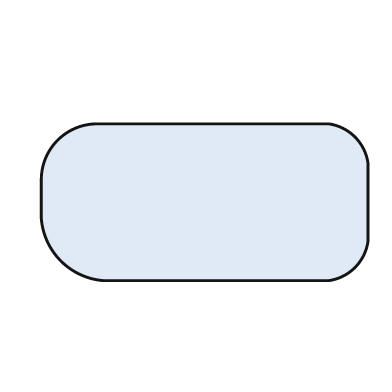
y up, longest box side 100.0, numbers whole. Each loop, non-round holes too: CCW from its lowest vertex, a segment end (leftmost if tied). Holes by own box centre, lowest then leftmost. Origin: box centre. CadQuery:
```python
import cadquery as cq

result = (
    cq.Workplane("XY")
    .moveTo(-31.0, -24.0)
    .lineTo(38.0, -24.0)
    .threePointArc((46.0, -20.0), (50.0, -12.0))
    .lineTo(50.0, 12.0)
    .threePointArc((46.0, 20.0), (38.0, 24.0))
    .lineTo(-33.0, 24.0)
    .threePointArc((-45.0, 19.0), (-50.0, 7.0))
    .lineTo(-50.0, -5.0)
    .threePointArc((-44.0, -18.0), (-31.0, -24.0))
    .close()
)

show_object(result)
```